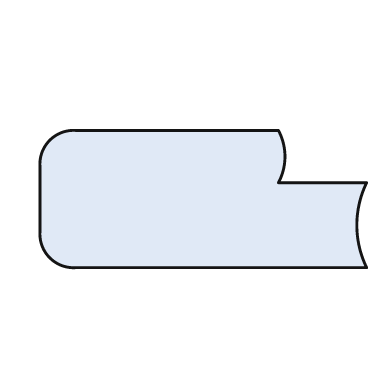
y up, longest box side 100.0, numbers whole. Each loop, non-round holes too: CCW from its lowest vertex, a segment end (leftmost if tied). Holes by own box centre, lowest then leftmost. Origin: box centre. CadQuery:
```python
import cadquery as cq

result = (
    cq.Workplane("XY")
    .moveTo(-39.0, -21.0)
    .lineTo(50.0, -21.0)
    .threePointArc((47.0, -8.0), (50.0, 5.0))
    .lineTo(23.0, 5.0)
    .threePointArc((25.0, 13.0), (23.0, 21.0))
    .lineTo(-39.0, 21.0)
    .threePointArc((-47.0, 18.0), (-50.0, 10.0))
    .lineTo(-50.0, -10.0)
    .threePointArc((-47.0, -18.0), (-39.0, -21.0))
    .close()
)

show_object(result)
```